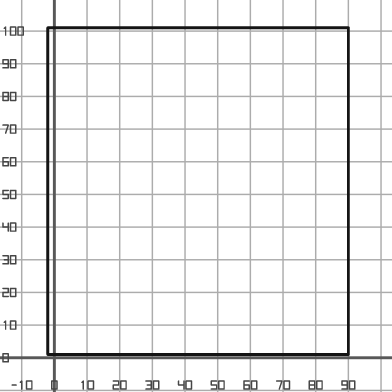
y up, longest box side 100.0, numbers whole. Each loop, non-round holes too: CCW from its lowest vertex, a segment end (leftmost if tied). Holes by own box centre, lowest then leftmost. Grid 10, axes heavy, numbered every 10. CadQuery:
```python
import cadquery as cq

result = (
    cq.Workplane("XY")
    .moveTo(-2.0, 1.0)
    .lineTo(90.0, 1.0)
    .lineTo(90.0, 101.0)
    .lineTo(-2.0, 101.0)
    .close()
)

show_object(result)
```